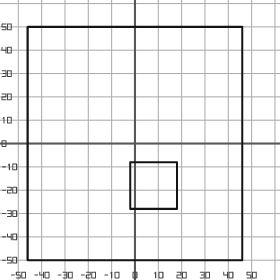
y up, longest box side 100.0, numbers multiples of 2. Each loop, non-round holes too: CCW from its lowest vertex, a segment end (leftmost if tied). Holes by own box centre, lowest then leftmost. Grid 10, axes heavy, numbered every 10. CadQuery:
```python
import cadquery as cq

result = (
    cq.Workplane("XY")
    .moveTo(-46.0, -50.0)
    .lineTo(46.0, -50.0)
    .lineTo(46.0, 50.0)
    .lineTo(-46.0, 50.0)
    .close()
    .moveTo(-2.0, -28.0)
    .lineTo(18.0, -28.0)
    .lineTo(18.0, -8.0)
    .lineTo(-2.0, -8.0)
    .close()
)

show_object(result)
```